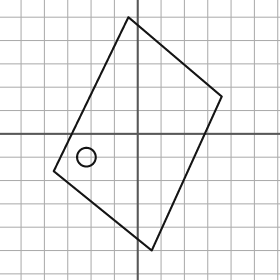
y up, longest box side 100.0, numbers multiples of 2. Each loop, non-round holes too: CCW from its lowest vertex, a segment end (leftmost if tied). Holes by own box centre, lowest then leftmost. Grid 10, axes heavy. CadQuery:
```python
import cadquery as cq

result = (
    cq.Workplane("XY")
    .moveTo(6.0, -50.0)
    .lineTo(36.0, 16.0)
    .lineTo(-4.0, 50.0)
    .lineTo(-36.0, -16.0)
    .close()
    .moveTo(-22.0, -10.0)
    .circle(4.0)
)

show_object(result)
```